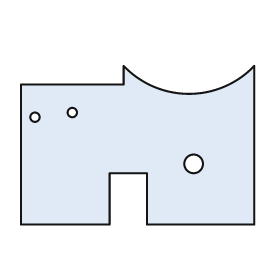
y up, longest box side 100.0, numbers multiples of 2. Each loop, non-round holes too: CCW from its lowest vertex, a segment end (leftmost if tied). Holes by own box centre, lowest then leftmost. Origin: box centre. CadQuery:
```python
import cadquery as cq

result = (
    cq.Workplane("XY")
    .moveTo(-50.0, -34.0)
    .lineTo(-12.0, -34.0)
    .lineTo(-12.0, -12.0)
    .lineTo(4.0, -12.0)
    .lineTo(4.0, -34.0)
    .lineTo(50.0, -34.0)
    .lineTo(50.0, 34.0)
    .threePointArc((22.0, 22.0), (-6.0, 34.0))
    .lineTo(-6.0, 26.0)
    .lineTo(-50.0, 26.0)
    .close()
    .moveTo(24.0, -8.0)
    .circle(4.0)
    .moveTo(-44.0, 12.0)
    .circle(2.0)
    .moveTo(-28.0, 14.0)
    .circle(2.0)
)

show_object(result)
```